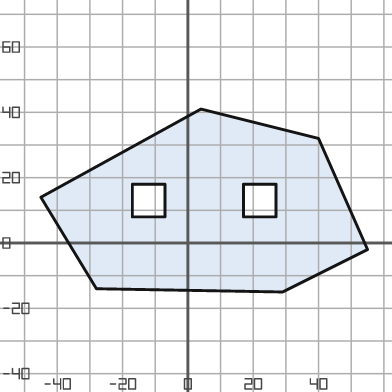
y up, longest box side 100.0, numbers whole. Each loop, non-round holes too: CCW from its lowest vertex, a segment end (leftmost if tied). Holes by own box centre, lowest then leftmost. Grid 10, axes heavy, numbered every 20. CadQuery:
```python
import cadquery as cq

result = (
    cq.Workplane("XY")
    .moveTo(29.0, -15.0)
    .lineTo(55.0, -2.0)
    .lineTo(40.0, 32.0)
    .lineTo(4.0, 41.0)
    .lineTo(-45.0, 14.0)
    .lineTo(-28.0, -14.0)
    .close()
    .moveTo(-17.0, 8.0)
    .lineTo(-7.0, 8.0)
    .lineTo(-7.0, 18.0)
    .lineTo(-17.0, 18.0)
    .close()
    .moveTo(17.0, 8.0)
    .lineTo(27.0, 8.0)
    .lineTo(27.0, 18.0)
    .lineTo(17.0, 18.0)
    .close()
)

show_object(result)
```